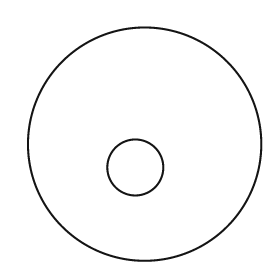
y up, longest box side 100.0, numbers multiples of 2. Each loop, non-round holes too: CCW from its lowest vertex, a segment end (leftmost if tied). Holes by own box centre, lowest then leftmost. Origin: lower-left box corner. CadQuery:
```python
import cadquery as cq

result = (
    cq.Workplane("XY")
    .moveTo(50.0, 50.0)
    .circle(50.0)
    .moveTo(46.0, 40.0)
    .circle(12.0)
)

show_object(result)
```